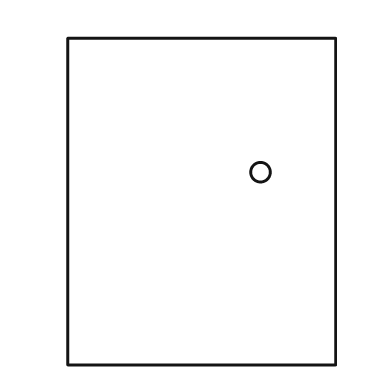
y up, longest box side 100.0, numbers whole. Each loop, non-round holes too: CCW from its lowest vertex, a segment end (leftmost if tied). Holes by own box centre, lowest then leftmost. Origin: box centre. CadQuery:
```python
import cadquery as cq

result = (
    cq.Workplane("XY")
    .moveTo(-41.0, -50.0)
    .lineTo(41.0, -50.0)
    .lineTo(41.0, 50.0)
    .lineTo(-41.0, 50.0)
    .close()
    .moveTo(18.0, 9.0)
    .circle(3.0)
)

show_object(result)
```